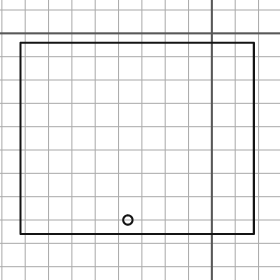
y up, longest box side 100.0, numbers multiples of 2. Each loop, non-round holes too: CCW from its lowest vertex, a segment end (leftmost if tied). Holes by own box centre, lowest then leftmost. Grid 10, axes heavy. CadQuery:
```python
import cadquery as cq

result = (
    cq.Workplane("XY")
    .moveTo(-82.0, -86.0)
    .lineTo(18.0, -86.0)
    .lineTo(18.0, -4.0)
    .lineTo(-82.0, -4.0)
    .close()
    .moveTo(-36.0, -80.0)
    .circle(2.0)
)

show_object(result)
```